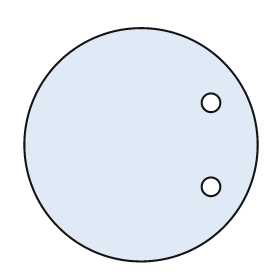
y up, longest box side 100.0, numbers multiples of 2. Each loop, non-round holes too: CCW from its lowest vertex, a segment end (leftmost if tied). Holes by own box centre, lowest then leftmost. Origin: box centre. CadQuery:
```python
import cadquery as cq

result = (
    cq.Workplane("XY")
    .moveTo(0.0, 0.0)
    .circle(50.0)
    .moveTo(30.0, -18.0)
    .circle(4.0)
    .moveTo(30.0, 18.0)
    .circle(4.0)
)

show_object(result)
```